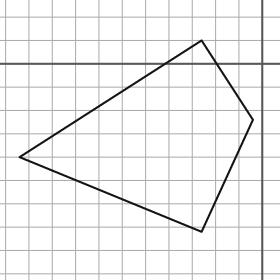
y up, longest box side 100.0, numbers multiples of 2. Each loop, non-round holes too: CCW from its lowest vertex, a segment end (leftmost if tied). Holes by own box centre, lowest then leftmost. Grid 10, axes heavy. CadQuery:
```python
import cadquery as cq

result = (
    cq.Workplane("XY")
    .moveTo(-26.0, -72.0)
    .lineTo(-4.0, -24.0)
    .lineTo(-26.0, 10.0)
    .lineTo(-104.0, -40.0)
    .close()
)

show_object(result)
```